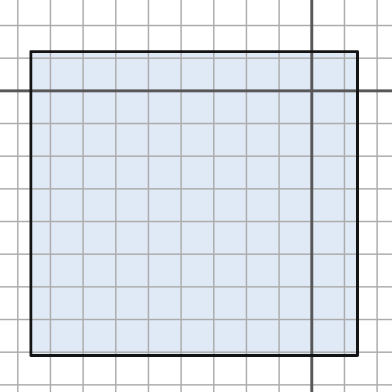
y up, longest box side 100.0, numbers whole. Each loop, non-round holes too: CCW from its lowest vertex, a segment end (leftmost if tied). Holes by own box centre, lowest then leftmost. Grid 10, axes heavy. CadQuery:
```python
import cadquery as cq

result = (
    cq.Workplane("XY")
    .moveTo(-86.0, -81.0)
    .lineTo(14.0, -81.0)
    .lineTo(14.0, 12.0)
    .lineTo(-86.0, 12.0)
    .close()
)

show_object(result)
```